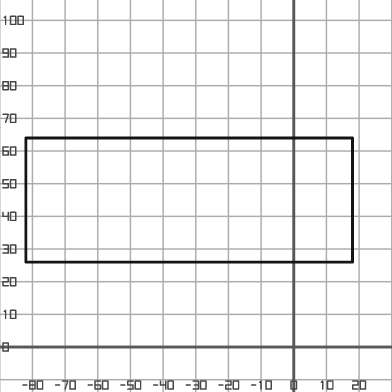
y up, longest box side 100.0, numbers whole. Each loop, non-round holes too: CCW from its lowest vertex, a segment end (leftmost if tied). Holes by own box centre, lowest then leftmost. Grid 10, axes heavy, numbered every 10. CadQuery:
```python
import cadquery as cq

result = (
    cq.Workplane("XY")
    .moveTo(-82.0, 26.0)
    .lineTo(18.0, 26.0)
    .lineTo(18.0, 64.0)
    .lineTo(-82.0, 64.0)
    .close()
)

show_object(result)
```